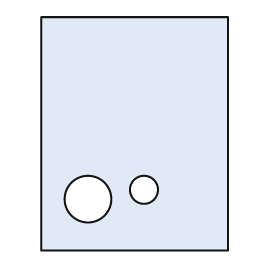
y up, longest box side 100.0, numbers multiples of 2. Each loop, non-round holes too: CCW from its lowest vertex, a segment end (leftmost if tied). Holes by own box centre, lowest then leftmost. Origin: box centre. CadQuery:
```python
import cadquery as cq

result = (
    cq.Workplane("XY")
    .moveTo(-40.0, -50.0)
    .lineTo(40.0, -50.0)
    .lineTo(40.0, 50.0)
    .lineTo(-40.0, 50.0)
    .close()
    .moveTo(-20.0, -28.0)
    .circle(10.0)
    .moveTo(4.0, -24.0)
    .circle(6.0)
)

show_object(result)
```